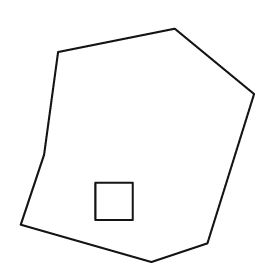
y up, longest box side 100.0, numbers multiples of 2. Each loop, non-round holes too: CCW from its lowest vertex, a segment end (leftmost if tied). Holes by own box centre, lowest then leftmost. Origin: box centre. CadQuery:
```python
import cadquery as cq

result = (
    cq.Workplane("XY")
    .moveTo(6.0, -50.0)
    .lineTo(30.0, -42.0)
    .lineTo(50.0, 22.0)
    .lineTo(16.0, 50.0)
    .lineTo(-34.0, 40.0)
    .lineTo(-40.0, -4.0)
    .lineTo(-50.0, -34.0)
    .close()
    .moveTo(-18.0, -32.0)
    .lineTo(-2.0, -32.0)
    .lineTo(-2.0, -16.0)
    .lineTo(-18.0, -16.0)
    .close()
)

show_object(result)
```